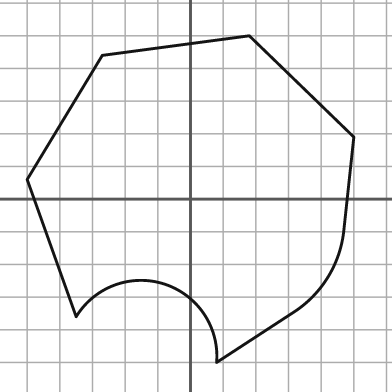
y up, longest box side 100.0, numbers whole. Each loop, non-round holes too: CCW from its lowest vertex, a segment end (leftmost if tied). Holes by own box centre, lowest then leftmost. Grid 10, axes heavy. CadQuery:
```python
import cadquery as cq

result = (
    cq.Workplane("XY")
    .moveTo(8.0, -50.0)
    .lineTo(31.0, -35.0)
    .threePointArc((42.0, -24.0), (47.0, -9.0))
    .lineTo(50.0, 19.0)
    .lineTo(18.0, 50.0)
    .lineTo(-27.0, 44.0)
    .lineTo(-50.0, 6.0)
    .lineTo(-35.0, -36.0)
    .threePointArc((-8.0, -26.0), (8.0, -50.0))
    .close()
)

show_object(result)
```